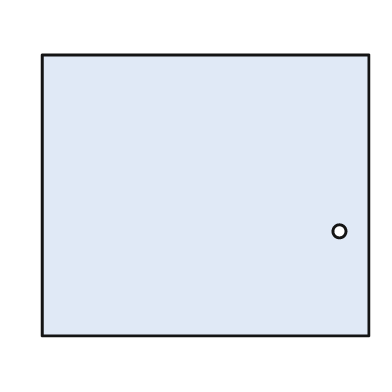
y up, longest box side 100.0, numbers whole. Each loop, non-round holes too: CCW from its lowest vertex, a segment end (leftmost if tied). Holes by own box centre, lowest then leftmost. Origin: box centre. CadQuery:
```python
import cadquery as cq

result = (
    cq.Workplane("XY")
    .moveTo(-50.0, -43.0)
    .lineTo(50.0, -43.0)
    .lineTo(50.0, 43.0)
    .lineTo(-50.0, 43.0)
    .close()
    .moveTo(41.0, -11.0)
    .circle(2.0)
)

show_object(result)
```